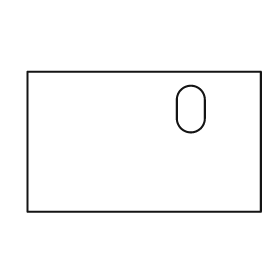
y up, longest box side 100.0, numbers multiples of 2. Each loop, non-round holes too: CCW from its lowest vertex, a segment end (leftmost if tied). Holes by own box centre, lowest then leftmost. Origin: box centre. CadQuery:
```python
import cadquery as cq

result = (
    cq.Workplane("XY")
    .moveTo(-50.0, -30.0)
    .lineTo(50.0, -30.0)
    .lineTo(50.0, 30.0)
    .lineTo(-50.0, 30.0)
    .close()
    .moveTo(14.0, 10.0)
    .threePointArc((20.0, 4.0), (26.0, 10.0))
    .lineTo(26.0, 18.0)
    .threePointArc((20.0, 24.0), (14.0, 18.0))
    .close()
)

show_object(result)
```